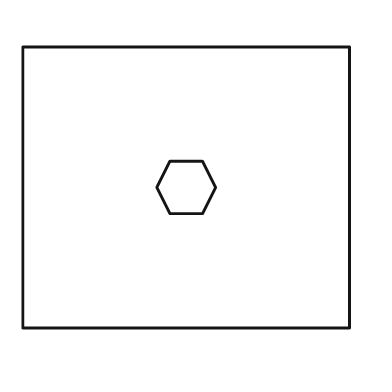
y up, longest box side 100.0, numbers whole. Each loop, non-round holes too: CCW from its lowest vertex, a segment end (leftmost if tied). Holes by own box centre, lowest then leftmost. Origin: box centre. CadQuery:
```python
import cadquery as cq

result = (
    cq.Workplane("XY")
    .moveTo(-50.0, -43.0)
    .lineTo(50.0, -43.0)
    .lineTo(50.0, 43.0)
    .lineTo(-50.0, 43.0)
    .close()
    .moveTo(-5.0, -8.0)
    .lineTo(5.0, -8.0)
    .lineTo(9.0, 0.0)
    .lineTo(5.0, 8.0)
    .lineTo(-5.0, 8.0)
    .lineTo(-9.0, 0.0)
    .close()
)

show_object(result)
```